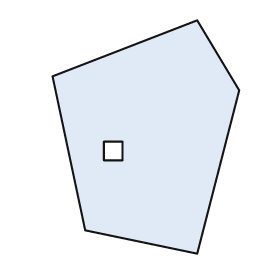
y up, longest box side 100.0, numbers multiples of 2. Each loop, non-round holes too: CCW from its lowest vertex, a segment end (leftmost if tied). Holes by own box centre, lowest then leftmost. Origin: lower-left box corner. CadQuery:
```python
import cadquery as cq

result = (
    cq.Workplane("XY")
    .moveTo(62.0, 0.0)
    .lineTo(80.0, 70.0)
    .lineTo(62.0, 100.0)
    .lineTo(0.0, 76.0)
    .lineTo(14.0, 10.0)
    .close()
    .moveTo(22.0, 40.0)
    .lineTo(30.0, 40.0)
    .lineTo(30.0, 48.0)
    .lineTo(22.0, 48.0)
    .close()
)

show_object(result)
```